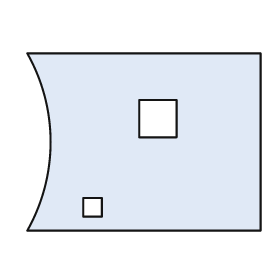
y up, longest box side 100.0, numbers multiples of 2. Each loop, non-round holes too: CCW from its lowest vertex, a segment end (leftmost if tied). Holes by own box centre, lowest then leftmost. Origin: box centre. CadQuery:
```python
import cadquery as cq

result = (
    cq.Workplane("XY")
    .moveTo(-50.0, -38.0)
    .lineTo(50.0, -38.0)
    .lineTo(50.0, 38.0)
    .lineTo(-50.0, 38.0)
    .threePointArc((-40.0, 0.0), (-50.0, -38.0))
    .close()
    .moveTo(-26.0, -32.0)
    .lineTo(-18.0, -32.0)
    .lineTo(-18.0, -24.0)
    .lineTo(-26.0, -24.0)
    .close()
    .moveTo(-2.0, 2.0)
    .lineTo(14.0, 2.0)
    .lineTo(14.0, 18.0)
    .lineTo(-2.0, 18.0)
    .close()
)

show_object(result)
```